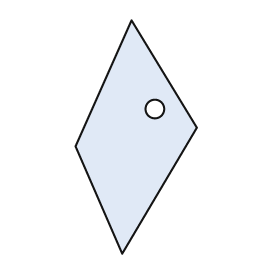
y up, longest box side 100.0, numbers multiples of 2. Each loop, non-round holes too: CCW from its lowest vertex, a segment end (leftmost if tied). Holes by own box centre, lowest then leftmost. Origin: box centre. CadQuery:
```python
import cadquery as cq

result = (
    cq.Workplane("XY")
    .moveTo(-6.0, -50.0)
    .lineTo(26.0, 4.0)
    .lineTo(-2.0, 50.0)
    .lineTo(-26.0, -4.0)
    .close()
    .moveTo(8.0, 12.0)
    .circle(4.0)
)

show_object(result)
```